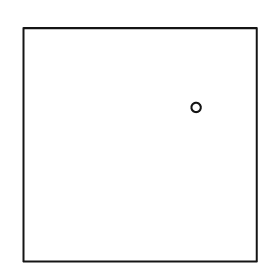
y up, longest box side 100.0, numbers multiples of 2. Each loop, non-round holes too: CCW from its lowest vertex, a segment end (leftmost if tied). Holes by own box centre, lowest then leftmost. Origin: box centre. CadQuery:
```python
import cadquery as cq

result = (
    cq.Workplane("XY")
    .moveTo(-50.0, -50.0)
    .lineTo(50.0, -50.0)
    .lineTo(50.0, 50.0)
    .lineTo(-50.0, 50.0)
    .close()
    .moveTo(24.0, 16.0)
    .circle(2.0)
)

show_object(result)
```